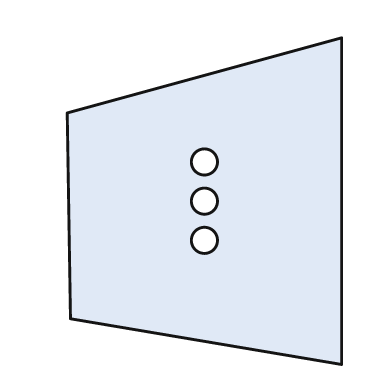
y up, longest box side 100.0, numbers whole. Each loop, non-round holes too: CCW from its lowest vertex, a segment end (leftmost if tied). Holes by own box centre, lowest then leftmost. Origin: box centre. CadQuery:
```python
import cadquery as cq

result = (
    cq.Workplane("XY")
    .moveTo(42.0, -50.0)
    .lineTo(42.0, 50.0)
    .lineTo(-42.0, 27.0)
    .lineTo(-41.0, -36.0)
    .close()
    .moveTo(0.0, -12.0)
    .circle(4.0)
    .moveTo(0.0, 0.0)
    .circle(4.0)
    .moveTo(0.0, 12.0)
    .circle(4.0)
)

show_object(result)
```